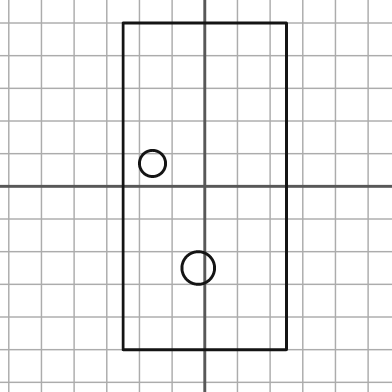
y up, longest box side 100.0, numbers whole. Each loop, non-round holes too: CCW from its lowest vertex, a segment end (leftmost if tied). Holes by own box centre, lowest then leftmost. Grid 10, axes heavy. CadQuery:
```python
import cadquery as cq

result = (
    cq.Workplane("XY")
    .moveTo(-25.0, -50.0)
    .lineTo(25.0, -50.0)
    .lineTo(25.0, 50.0)
    .lineTo(-25.0, 50.0)
    .close()
    .moveTo(-2.0, -25.0)
    .circle(5.0)
    .moveTo(-16.0, 7.0)
    .circle(4.0)
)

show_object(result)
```